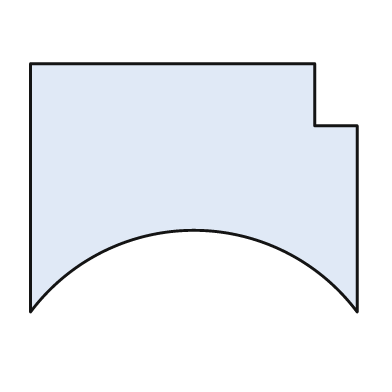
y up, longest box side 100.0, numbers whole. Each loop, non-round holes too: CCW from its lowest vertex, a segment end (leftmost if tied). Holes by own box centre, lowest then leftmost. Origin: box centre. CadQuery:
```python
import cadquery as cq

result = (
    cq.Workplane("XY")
    .moveTo(-50.0, -38.0)
    .threePointArc((0.0, -13.0), (50.0, -38.0))
    .lineTo(50.0, 19.0)
    .lineTo(37.0, 19.0)
    .lineTo(37.0, 38.0)
    .lineTo(-50.0, 38.0)
    .close()
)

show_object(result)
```